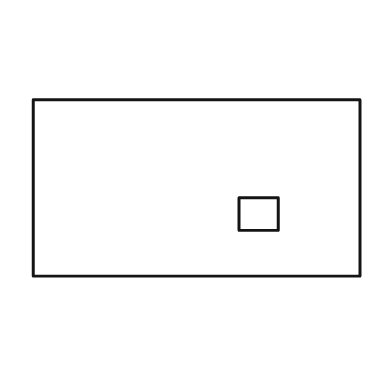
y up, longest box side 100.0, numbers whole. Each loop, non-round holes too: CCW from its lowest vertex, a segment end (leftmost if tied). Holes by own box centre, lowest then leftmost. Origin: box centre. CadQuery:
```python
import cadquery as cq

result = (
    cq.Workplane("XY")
    .moveTo(-50.0, -27.0)
    .lineTo(50.0, -27.0)
    .lineTo(50.0, 27.0)
    .lineTo(-50.0, 27.0)
    .close()
    .moveTo(13.0, -13.0)
    .lineTo(25.0, -13.0)
    .lineTo(25.0, -3.0)
    .lineTo(13.0, -3.0)
    .close()
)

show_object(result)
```